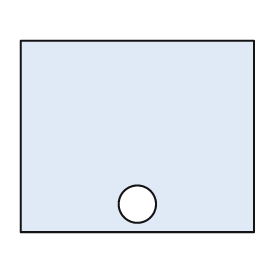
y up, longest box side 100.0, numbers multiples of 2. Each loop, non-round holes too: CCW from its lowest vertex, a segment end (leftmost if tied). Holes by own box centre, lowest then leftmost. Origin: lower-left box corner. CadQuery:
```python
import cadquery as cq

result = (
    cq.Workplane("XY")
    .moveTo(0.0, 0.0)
    .lineTo(100.0, 0.0)
    .lineTo(100.0, 82.0)
    .lineTo(0.0, 82.0)
    .close()
    .moveTo(50.0, 12.0)
    .circle(8.0)
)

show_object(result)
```